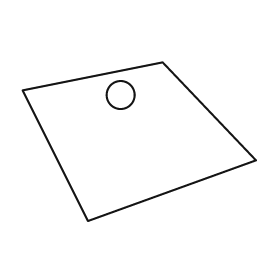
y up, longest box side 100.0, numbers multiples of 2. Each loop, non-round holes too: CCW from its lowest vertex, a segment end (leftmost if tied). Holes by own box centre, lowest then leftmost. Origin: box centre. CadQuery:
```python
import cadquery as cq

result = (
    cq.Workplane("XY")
    .moveTo(-22.0, -34.0)
    .lineTo(50.0, -8.0)
    .lineTo(10.0, 34.0)
    .lineTo(-50.0, 22.0)
    .close()
    .moveTo(-8.0, 20.0)
    .circle(6.0)
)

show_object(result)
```